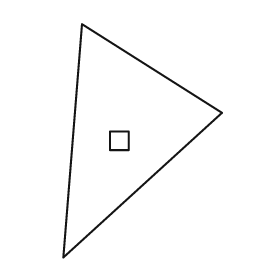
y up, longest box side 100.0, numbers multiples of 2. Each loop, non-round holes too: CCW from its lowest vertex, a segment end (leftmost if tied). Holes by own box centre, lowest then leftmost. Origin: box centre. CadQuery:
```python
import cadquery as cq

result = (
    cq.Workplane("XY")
    .moveTo(-34.0, -50.0)
    .lineTo(34.0, 12.0)
    .lineTo(-26.0, 50.0)
    .close()
    .moveTo(-14.0, -4.0)
    .lineTo(-6.0, -4.0)
    .lineTo(-6.0, 4.0)
    .lineTo(-14.0, 4.0)
    .close()
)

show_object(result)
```